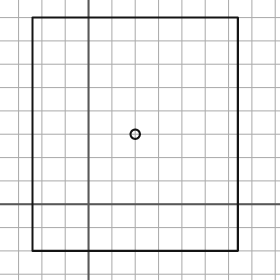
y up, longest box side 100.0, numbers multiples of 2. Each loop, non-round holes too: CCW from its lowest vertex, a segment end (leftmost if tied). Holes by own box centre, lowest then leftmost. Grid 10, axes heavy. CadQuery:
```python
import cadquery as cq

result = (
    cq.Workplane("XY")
    .moveTo(-24.0, -20.0)
    .lineTo(64.0, -20.0)
    .lineTo(64.0, 80.0)
    .lineTo(-24.0, 80.0)
    .close()
    .moveTo(20.0, 30.0)
    .circle(2.0)
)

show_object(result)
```